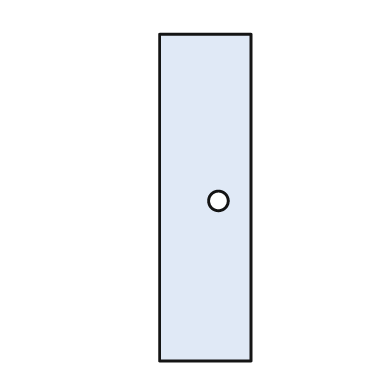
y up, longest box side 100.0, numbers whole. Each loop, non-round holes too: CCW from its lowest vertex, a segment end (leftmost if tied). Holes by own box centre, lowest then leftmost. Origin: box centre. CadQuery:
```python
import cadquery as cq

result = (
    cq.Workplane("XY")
    .moveTo(-14.0, -50.0)
    .lineTo(14.0, -50.0)
    .lineTo(14.0, 50.0)
    .lineTo(-14.0, 50.0)
    .close()
    .moveTo(4.0, -1.0)
    .circle(3.0)
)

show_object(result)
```